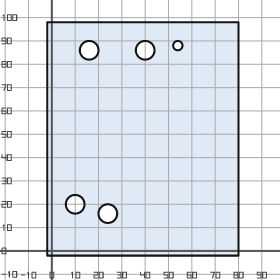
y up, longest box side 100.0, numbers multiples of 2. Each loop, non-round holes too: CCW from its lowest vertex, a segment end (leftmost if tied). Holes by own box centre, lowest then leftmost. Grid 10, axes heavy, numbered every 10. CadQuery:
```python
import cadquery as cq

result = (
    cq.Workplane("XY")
    .moveTo(-2.0, -2.0)
    .lineTo(80.0, -2.0)
    .lineTo(80.0, 98.0)
    .lineTo(-2.0, 98.0)
    .close()
    .moveTo(24.0, 16.0)
    .circle(4.0)
    .moveTo(10.0, 20.0)
    .circle(4.0)
    .moveTo(16.0, 86.0)
    .circle(4.0)
    .moveTo(40.0, 86.0)
    .circle(4.0)
    .moveTo(54.0, 88.0)
    .circle(2.0)
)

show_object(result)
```